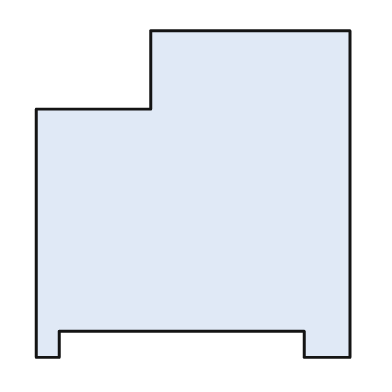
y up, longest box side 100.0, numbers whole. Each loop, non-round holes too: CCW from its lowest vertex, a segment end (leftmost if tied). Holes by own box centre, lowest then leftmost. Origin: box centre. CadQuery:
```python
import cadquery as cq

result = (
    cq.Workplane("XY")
    .moveTo(-48.0, -50.0)
    .lineTo(-41.0, -50.0)
    .lineTo(-41.0, -42.0)
    .lineTo(34.0, -42.0)
    .lineTo(34.0, -50.0)
    .lineTo(48.0, -50.0)
    .lineTo(48.0, 50.0)
    .lineTo(-13.0, 50.0)
    .lineTo(-13.0, 26.0)
    .lineTo(-48.0, 26.0)
    .close()
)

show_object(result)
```